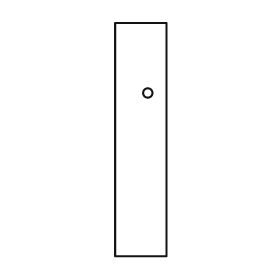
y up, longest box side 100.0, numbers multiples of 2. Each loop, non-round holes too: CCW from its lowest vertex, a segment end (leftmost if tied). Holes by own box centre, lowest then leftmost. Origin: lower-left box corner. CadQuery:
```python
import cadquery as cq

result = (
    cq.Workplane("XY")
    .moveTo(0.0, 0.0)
    .lineTo(22.0, 0.0)
    .lineTo(22.0, 100.0)
    .lineTo(0.0, 100.0)
    .close()
    .moveTo(14.0, 70.0)
    .circle(2.0)
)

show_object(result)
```